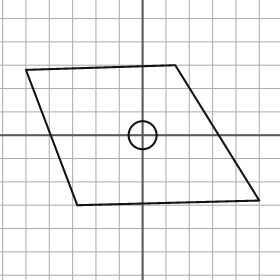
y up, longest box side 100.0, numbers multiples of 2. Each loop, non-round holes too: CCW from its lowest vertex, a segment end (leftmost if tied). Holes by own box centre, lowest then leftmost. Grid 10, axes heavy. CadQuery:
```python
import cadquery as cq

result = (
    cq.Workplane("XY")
    .moveTo(-28.0, -30.0)
    .lineTo(50.0, -28.0)
    .lineTo(14.0, 30.0)
    .lineTo(-50.0, 28.0)
    .close()
    .moveTo(0.0, 0.0)
    .circle(6.0)
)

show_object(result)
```